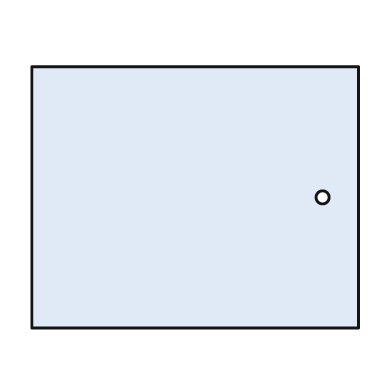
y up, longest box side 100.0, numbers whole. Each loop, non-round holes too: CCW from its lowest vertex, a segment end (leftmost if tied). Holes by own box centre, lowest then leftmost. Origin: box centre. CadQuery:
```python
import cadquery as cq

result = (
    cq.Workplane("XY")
    .moveTo(-50.0, -40.0)
    .lineTo(50.0, -40.0)
    .lineTo(50.0, 40.0)
    .lineTo(-50.0, 40.0)
    .close()
    .moveTo(39.0, 0.0)
    .circle(2.0)
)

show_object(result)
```